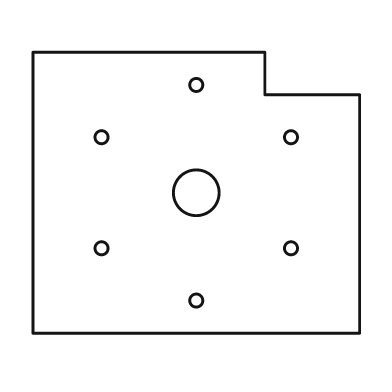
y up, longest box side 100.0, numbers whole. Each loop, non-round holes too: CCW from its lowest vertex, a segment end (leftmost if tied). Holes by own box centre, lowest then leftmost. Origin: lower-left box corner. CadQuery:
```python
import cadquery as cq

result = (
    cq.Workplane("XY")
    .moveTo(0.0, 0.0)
    .lineTo(100.0, 0.0)
    .lineTo(100.0, 73.0)
    .lineTo(71.0, 73.0)
    .lineTo(71.0, 86.0)
    .lineTo(0.0, 86.0)
    .close()
    .moveTo(50.0, 10.0)
    .circle(2.0)
    .moveTo(21.0, 26.0)
    .circle(2.0)
    .moveTo(79.0, 26.0)
    .circle(2.0)
    .moveTo(50.0, 43.0)
    .circle(7.0)
    .moveTo(21.0, 60.0)
    .circle(2.0)
    .moveTo(79.0, 60.0)
    .circle(2.0)
    .moveTo(50.0, 76.0)
    .circle(2.0)
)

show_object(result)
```